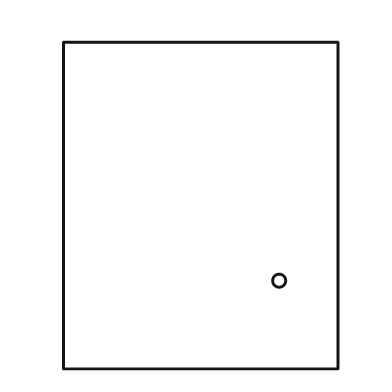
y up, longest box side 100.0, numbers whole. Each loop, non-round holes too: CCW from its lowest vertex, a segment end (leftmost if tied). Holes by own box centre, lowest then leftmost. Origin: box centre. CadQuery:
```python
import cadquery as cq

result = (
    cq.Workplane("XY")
    .moveTo(-42.0, -50.0)
    .lineTo(42.0, -50.0)
    .lineTo(42.0, 50.0)
    .lineTo(-42.0, 50.0)
    .close()
    .moveTo(24.0, -23.0)
    .circle(2.0)
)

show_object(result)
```